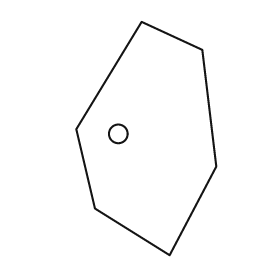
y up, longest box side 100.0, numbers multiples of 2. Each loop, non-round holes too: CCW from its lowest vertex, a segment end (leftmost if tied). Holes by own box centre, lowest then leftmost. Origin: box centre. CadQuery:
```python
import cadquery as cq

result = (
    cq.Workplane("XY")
    .moveTo(10.0, -50.0)
    .lineTo(30.0, -12.0)
    .lineTo(24.0, 38.0)
    .lineTo(-2.0, 50.0)
    .lineTo(-30.0, 4.0)
    .lineTo(-22.0, -30.0)
    .close()
    .moveTo(-12.0, 2.0)
    .circle(4.0)
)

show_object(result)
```